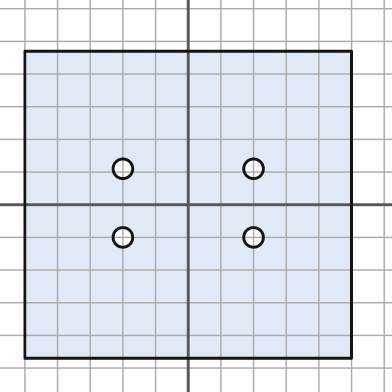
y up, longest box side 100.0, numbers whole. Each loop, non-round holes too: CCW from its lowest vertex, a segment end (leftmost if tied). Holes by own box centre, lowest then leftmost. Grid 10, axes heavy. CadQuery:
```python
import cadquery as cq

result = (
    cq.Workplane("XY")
    .moveTo(-50.0, -47.0)
    .lineTo(50.0, -47.0)
    .lineTo(50.0, 47.0)
    .lineTo(-50.0, 47.0)
    .close()
    .moveTo(-20.0, -10.0)
    .circle(3.0)
    .moveTo(20.0, -10.0)
    .circle(3.0)
    .moveTo(-20.0, 11.0)
    .circle(3.0)
    .moveTo(20.0, 11.0)
    .circle(3.0)
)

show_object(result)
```